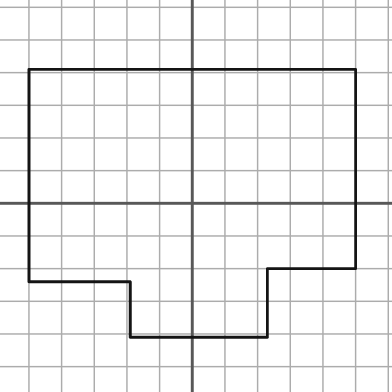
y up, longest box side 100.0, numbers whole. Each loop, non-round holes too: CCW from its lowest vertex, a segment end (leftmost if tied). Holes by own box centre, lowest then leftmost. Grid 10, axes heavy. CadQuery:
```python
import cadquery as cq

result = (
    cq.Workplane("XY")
    .moveTo(-19.0, -41.0)
    .lineTo(23.0, -41.0)
    .lineTo(23.0, -20.0)
    .lineTo(50.0, -20.0)
    .lineTo(50.0, 41.0)
    .lineTo(-50.0, 41.0)
    .lineTo(-50.0, -24.0)
    .lineTo(-19.0, -24.0)
    .close()
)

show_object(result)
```